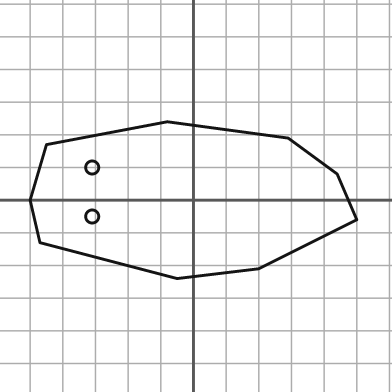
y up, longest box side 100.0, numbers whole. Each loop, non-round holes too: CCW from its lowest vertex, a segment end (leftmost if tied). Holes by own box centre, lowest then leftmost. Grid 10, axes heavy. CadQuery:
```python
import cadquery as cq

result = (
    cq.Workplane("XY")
    .moveTo(-5.0, -24.0)
    .lineTo(20.0, -21.0)
    .lineTo(50.0, -6.0)
    .lineTo(44.0, 8.0)
    .lineTo(29.0, 19.0)
    .lineTo(-8.0, 24.0)
    .lineTo(-45.0, 17.0)
    .lineTo(-50.0, 0.0)
    .lineTo(-47.0, -13.0)
    .close()
    .moveTo(-31.0, -5.0)
    .circle(2.0)
    .moveTo(-31.0, 10.0)
    .circle(2.0)
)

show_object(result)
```